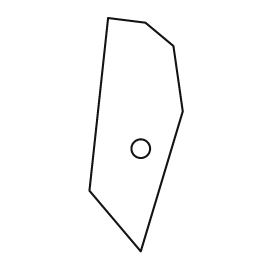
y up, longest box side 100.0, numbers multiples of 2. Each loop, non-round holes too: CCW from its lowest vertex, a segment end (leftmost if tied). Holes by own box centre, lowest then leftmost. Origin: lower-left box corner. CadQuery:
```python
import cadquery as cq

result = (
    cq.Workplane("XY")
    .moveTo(22.0, 0.0)
    .lineTo(40.0, 60.0)
    .lineTo(36.0, 88.0)
    .lineTo(24.0, 98.0)
    .lineTo(8.0, 100.0)
    .lineTo(0.0, 26.0)
    .close()
    .moveTo(22.0, 44.0)
    .circle(4.0)
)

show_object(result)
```